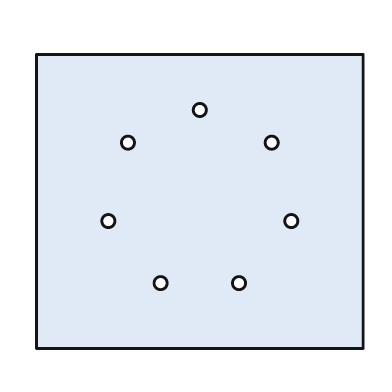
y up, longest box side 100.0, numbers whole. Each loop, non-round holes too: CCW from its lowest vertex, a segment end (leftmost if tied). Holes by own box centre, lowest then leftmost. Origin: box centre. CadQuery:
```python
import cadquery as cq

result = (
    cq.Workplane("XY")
    .moveTo(-50.0, -45.0)
    .lineTo(50.0, -45.0)
    .lineTo(50.0, 45.0)
    .lineTo(-50.0, 45.0)
    .close()
    .moveTo(-12.0, -25.0)
    .circle(2.0)
    .moveTo(12.0, -25.0)
    .circle(2.0)
    .moveTo(-28.0, -6.0)
    .circle(2.0)
    .moveTo(28.0, -6.0)
    .circle(2.0)
    .moveTo(-22.0, 18.0)
    .circle(2.0)
    .moveTo(22.0, 18.0)
    .circle(2.0)
    .moveTo(0.0, 28.0)
    .circle(2.0)
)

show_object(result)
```